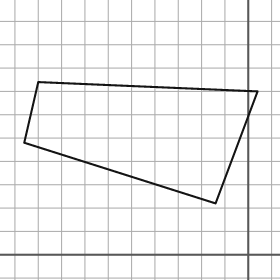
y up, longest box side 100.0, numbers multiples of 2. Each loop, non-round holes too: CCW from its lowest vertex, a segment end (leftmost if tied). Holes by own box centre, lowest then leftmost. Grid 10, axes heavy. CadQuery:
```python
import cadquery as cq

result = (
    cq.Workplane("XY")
    .moveTo(-14.0, 22.0)
    .lineTo(4.0, 70.0)
    .lineTo(-90.0, 74.0)
    .lineTo(-96.0, 48.0)
    .close()
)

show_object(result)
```